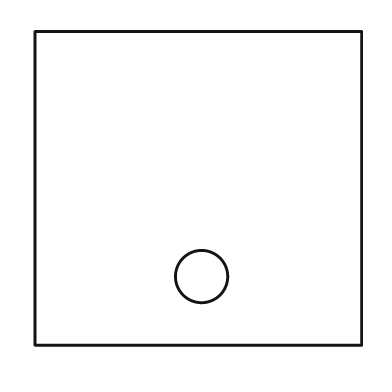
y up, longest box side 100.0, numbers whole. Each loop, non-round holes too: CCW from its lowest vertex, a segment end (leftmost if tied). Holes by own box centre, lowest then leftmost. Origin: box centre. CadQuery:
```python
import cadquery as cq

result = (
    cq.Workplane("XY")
    .moveTo(-50.0, -48.0)
    .lineTo(50.0, -48.0)
    .lineTo(50.0, 48.0)
    .lineTo(-50.0, 48.0)
    .close()
    .moveTo(1.0, -27.0)
    .circle(8.0)
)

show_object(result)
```